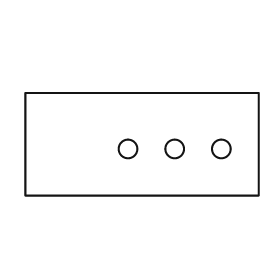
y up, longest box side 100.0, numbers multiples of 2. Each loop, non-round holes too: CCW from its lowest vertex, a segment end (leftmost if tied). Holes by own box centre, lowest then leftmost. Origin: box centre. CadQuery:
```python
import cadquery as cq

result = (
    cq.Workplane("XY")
    .moveTo(-50.0, -22.0)
    .lineTo(50.0, -22.0)
    .lineTo(50.0, 22.0)
    .lineTo(-50.0, 22.0)
    .close()
    .moveTo(-6.0, -2.0)
    .circle(4.0)
    .moveTo(14.0, -2.0)
    .circle(4.0)
    .moveTo(34.0, -2.0)
    .circle(4.0)
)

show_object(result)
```